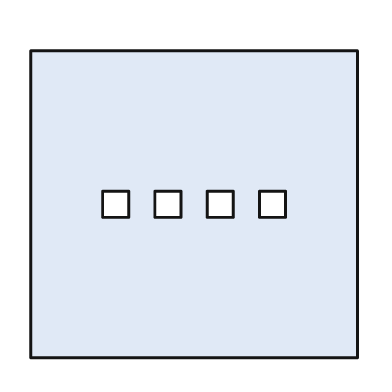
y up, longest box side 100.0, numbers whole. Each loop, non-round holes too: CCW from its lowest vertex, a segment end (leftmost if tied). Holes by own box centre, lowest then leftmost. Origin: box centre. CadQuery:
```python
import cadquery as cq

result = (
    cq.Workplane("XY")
    .moveTo(-50.0, -47.0)
    .lineTo(50.0, -47.0)
    .lineTo(50.0, 47.0)
    .lineTo(-50.0, 47.0)
    .close()
    .moveTo(-28.0, -4.0)
    .lineTo(-20.0, -4.0)
    .lineTo(-20.0, 4.0)
    .lineTo(-28.0, 4.0)
    .close()
    .moveTo(-12.0, -4.0)
    .lineTo(-4.0, -4.0)
    .lineTo(-4.0, 4.0)
    .lineTo(-12.0, 4.0)
    .close()
    .moveTo(4.0, -4.0)
    .lineTo(12.0, -4.0)
    .lineTo(12.0, 4.0)
    .lineTo(4.0, 4.0)
    .close()
    .moveTo(20.0, -4.0)
    .lineTo(28.0, -4.0)
    .lineTo(28.0, 4.0)
    .lineTo(20.0, 4.0)
    .close()
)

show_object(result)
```